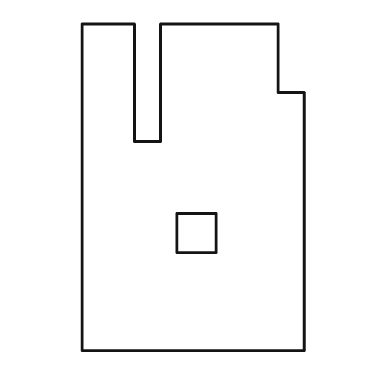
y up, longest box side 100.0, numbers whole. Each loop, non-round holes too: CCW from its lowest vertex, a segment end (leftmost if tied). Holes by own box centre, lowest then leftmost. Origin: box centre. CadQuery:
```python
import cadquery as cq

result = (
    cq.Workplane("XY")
    .moveTo(-34.0, -50.0)
    .lineTo(34.0, -50.0)
    .lineTo(34.0, 29.0)
    .lineTo(26.0, 29.0)
    .lineTo(26.0, 50.0)
    .lineTo(-10.0, 50.0)
    .lineTo(-10.0, 14.0)
    .lineTo(-18.0, 14.0)
    .lineTo(-18.0, 50.0)
    .lineTo(-34.0, 50.0)
    .close()
    .moveTo(-5.0, -20.0)
    .lineTo(7.0, -20.0)
    .lineTo(7.0, -8.0)
    .lineTo(-5.0, -8.0)
    .close()
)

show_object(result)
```